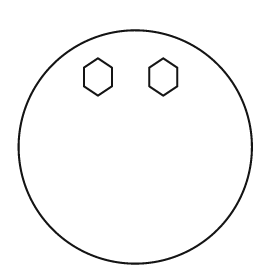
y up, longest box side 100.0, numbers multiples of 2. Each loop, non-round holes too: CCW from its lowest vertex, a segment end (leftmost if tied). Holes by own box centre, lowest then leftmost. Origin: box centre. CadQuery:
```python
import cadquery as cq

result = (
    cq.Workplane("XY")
    .moveTo(0.0, 0.0)
    .circle(50.0)
    .moveTo(-16.0, 22.0)
    .lineTo(-10.0, 26.0)
    .lineTo(-10.0, 34.0)
    .lineTo(-16.0, 38.0)
    .lineTo(-22.0, 34.0)
    .lineTo(-22.0, 26.0)
    .close()
    .moveTo(12.0, 22.0)
    .lineTo(18.0, 26.0)
    .lineTo(18.0, 34.0)
    .lineTo(12.0, 38.0)
    .lineTo(6.0, 34.0)
    .lineTo(6.0, 26.0)
    .close()
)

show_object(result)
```